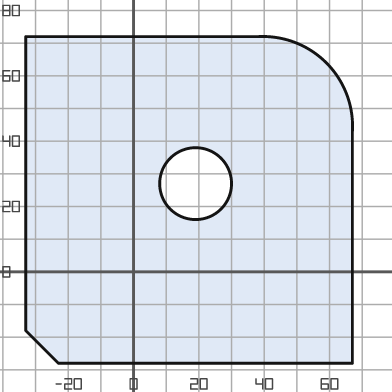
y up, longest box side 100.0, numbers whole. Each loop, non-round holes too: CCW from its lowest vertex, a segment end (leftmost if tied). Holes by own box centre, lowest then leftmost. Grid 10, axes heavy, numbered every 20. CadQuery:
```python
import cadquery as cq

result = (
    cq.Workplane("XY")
    .moveTo(-23.0, -28.0)
    .lineTo(67.0, -28.0)
    .lineTo(67.0, 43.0)
    .threePointArc((59.0, 64.0), (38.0, 72.0))
    .lineTo(-33.0, 72.0)
    .lineTo(-33.0, -18.0)
    .close()
    .moveTo(19.0, 27.0)
    .circle(11.0)
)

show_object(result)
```